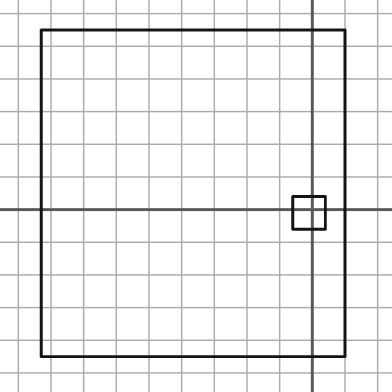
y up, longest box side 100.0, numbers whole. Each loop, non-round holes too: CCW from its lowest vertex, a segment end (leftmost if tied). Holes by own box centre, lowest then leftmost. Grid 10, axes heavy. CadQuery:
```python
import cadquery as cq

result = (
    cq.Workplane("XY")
    .moveTo(-83.0, -45.0)
    .lineTo(10.0, -45.0)
    .lineTo(10.0, 55.0)
    .lineTo(-83.0, 55.0)
    .close()
    .moveTo(-6.0, -6.0)
    .lineTo(4.0, -6.0)
    .lineTo(4.0, 4.0)
    .lineTo(-6.0, 4.0)
    .close()
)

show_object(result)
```